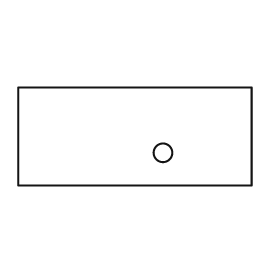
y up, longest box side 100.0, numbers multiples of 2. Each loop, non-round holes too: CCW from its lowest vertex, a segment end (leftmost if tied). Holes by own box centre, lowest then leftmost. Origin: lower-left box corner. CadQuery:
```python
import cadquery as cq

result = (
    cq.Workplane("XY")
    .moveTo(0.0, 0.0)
    .lineTo(100.0, 0.0)
    .lineTo(100.0, 42.0)
    .lineTo(0.0, 42.0)
    .close()
    .moveTo(62.0, 14.0)
    .circle(4.0)
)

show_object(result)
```